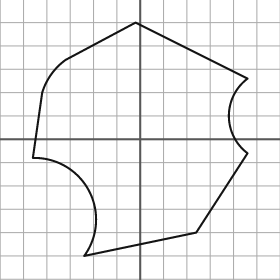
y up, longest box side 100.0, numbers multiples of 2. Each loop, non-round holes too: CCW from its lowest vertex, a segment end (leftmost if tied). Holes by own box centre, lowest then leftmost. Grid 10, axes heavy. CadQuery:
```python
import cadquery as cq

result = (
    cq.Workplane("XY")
    .moveTo(-24.0, -50.0)
    .lineTo(24.0, -40.0)
    .lineTo(46.0, -6.0)
    .threePointArc((38.0, 10.0), (46.0, 26.0))
    .lineTo(-2.0, 50.0)
    .lineTo(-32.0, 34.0)
    .threePointArc((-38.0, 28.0), (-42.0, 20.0))
    .lineTo(-46.0, -8.0)
    .threePointArc((-22.0, -22.0), (-24.0, -50.0))
    .close()
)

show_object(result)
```